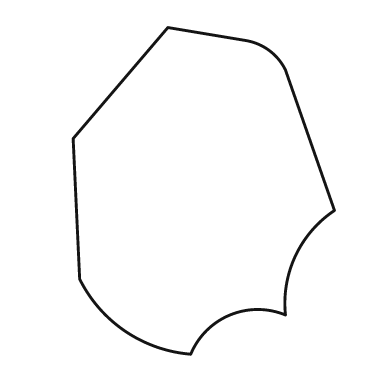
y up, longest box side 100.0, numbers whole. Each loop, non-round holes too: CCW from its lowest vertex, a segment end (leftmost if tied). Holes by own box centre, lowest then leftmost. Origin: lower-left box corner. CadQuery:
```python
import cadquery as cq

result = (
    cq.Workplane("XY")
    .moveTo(36.0, 0.0)
    .threePointArc((48.0, 12.0), (65.0, 12.0))
    .threePointArc((68.0, 30.0), (80.0, 44.0))
    .lineTo(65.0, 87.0)
    .threePointArc((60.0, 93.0), (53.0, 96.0))
    .lineTo(29.0, 100.0)
    .lineTo(0.0, 66.0)
    .lineTo(2.0, 23.0)
    .threePointArc((16.0, 7.0), (36.0, 0.0))
    .close()
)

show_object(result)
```